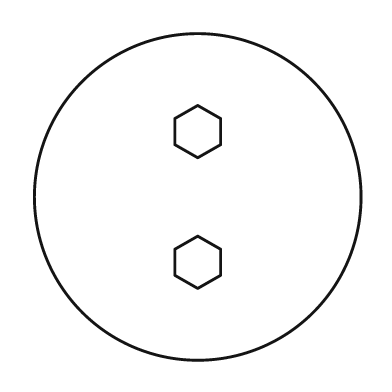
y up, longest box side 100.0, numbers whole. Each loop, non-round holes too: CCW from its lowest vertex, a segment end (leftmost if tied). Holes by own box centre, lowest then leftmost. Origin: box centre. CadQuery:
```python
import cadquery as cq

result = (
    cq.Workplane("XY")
    .moveTo(0.0, 0.0)
    .circle(50.0)
    .moveTo(0.0, -28.0)
    .lineTo(7.0, -24.0)
    .lineTo(7.0, -16.0)
    .lineTo(0.0, -12.0)
    .lineTo(-7.0, -16.0)
    .lineTo(-7.0, -24.0)
    .close()
    .moveTo(0.0, 12.0)
    .lineTo(7.0, 16.0)
    .lineTo(7.0, 24.0)
    .lineTo(0.0, 28.0)
    .lineTo(-7.0, 24.0)
    .lineTo(-7.0, 16.0)
    .close()
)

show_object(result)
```